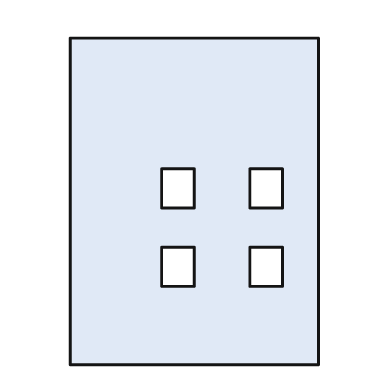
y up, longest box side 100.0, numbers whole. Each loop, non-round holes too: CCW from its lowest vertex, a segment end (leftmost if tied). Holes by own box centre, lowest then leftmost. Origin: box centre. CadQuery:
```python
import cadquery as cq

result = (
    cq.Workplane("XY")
    .moveTo(-38.0, -50.0)
    .lineTo(38.0, -50.0)
    .lineTo(38.0, 50.0)
    .lineTo(-38.0, 50.0)
    .close()
    .moveTo(-10.0, -26.0)
    .lineTo(0.0, -26.0)
    .lineTo(0.0, -14.0)
    .lineTo(-10.0, -14.0)
    .close()
    .moveTo(17.0, -26.0)
    .lineTo(27.0, -26.0)
    .lineTo(27.0, -14.0)
    .lineTo(17.0, -14.0)
    .close()
    .moveTo(-10.0, -2.0)
    .lineTo(0.0, -2.0)
    .lineTo(0.0, 10.0)
    .lineTo(-10.0, 10.0)
    .close()
    .moveTo(17.0, -2.0)
    .lineTo(27.0, -2.0)
    .lineTo(27.0, 10.0)
    .lineTo(17.0, 10.0)
    .close()
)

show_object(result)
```